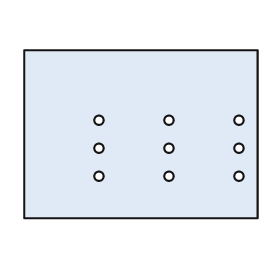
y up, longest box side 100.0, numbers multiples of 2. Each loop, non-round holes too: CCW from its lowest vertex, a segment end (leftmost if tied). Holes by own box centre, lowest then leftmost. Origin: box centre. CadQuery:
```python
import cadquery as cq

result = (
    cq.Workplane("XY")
    .moveTo(-50.0, -36.0)
    .lineTo(50.0, -36.0)
    .lineTo(50.0, 36.0)
    .lineTo(-50.0, 36.0)
    .close()
    .moveTo(-18.0, -18.0)
    .circle(2.0)
    .moveTo(12.0, -18.0)
    .circle(2.0)
    .moveTo(42.0, -18.0)
    .circle(2.0)
    .moveTo(-18.0, -6.0)
    .circle(2.0)
    .moveTo(12.0, -6.0)
    .circle(2.0)
    .moveTo(42.0, -6.0)
    .circle(2.0)
    .moveTo(-18.0, 6.0)
    .circle(2.0)
    .moveTo(12.0, 6.0)
    .circle(2.0)
    .moveTo(42.0, 6.0)
    .circle(2.0)
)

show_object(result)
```